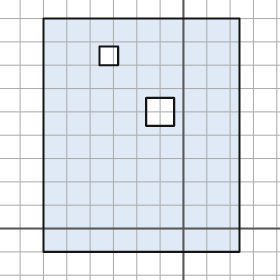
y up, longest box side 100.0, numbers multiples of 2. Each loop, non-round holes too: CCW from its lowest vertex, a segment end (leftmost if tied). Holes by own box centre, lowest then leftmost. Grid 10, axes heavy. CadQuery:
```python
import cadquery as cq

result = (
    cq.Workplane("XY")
    .moveTo(-60.0, -10.0)
    .lineTo(24.0, -10.0)
    .lineTo(24.0, 90.0)
    .lineTo(-60.0, 90.0)
    .close()
    .moveTo(-16.0, 44.0)
    .lineTo(-4.0, 44.0)
    .lineTo(-4.0, 56.0)
    .lineTo(-16.0, 56.0)
    .close()
    .moveTo(-36.0, 70.0)
    .lineTo(-28.0, 70.0)
    .lineTo(-28.0, 78.0)
    .lineTo(-36.0, 78.0)
    .close()
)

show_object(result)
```